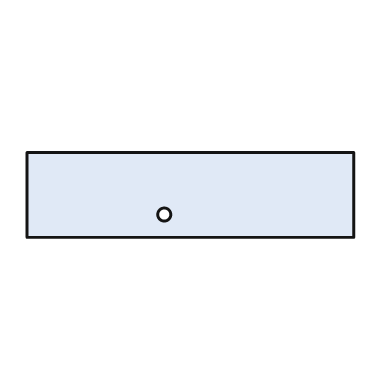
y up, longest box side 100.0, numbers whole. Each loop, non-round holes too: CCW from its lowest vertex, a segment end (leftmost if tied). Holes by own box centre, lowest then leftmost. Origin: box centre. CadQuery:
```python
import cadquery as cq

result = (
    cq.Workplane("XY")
    .moveTo(-50.0, -13.0)
    .lineTo(50.0, -13.0)
    .lineTo(50.0, 13.0)
    .lineTo(-50.0, 13.0)
    .close()
    .moveTo(-8.0, -6.0)
    .circle(2.0)
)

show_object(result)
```